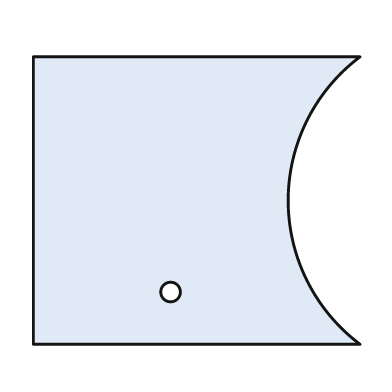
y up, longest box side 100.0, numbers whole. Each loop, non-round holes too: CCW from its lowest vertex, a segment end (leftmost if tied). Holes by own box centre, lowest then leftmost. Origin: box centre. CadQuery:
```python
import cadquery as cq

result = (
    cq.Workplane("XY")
    .moveTo(-50.0, -44.0)
    .lineTo(50.0, -44.0)
    .threePointArc((28.0, 0.0), (50.0, 44.0))
    .lineTo(-50.0, 44.0)
    .close()
    .moveTo(-8.0, -28.0)
    .circle(3.0)
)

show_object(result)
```